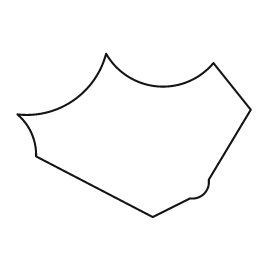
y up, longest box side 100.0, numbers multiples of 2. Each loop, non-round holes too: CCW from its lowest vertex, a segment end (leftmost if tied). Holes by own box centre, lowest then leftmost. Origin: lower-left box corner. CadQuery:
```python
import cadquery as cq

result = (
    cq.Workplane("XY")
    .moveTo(58.0, 0.0)
    .lineTo(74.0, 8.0)
    .threePointArc((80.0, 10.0), (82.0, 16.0))
    .lineTo(100.0, 46.0)
    .lineTo(84.0, 66.0)
    .threePointArc((60.0, 56.0), (38.0, 70.0))
    .threePointArc((24.0, 50.0), (0.0, 44.0))
    .threePointArc((6.0, 36.0), (8.0, 26.0))
    .close()
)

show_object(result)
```